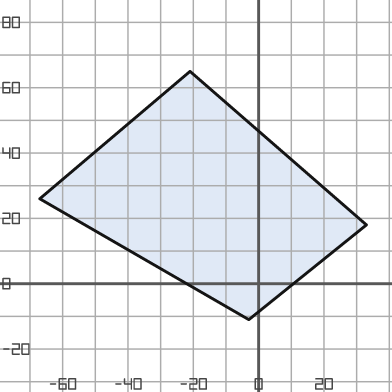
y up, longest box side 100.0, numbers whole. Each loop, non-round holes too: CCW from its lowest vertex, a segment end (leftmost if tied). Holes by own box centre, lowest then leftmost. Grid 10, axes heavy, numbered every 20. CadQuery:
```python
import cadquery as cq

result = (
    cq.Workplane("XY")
    .moveTo(-3.0, -11.0)
    .lineTo(33.0, 18.0)
    .lineTo(-21.0, 65.0)
    .lineTo(-67.0, 26.0)
    .close()
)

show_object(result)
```